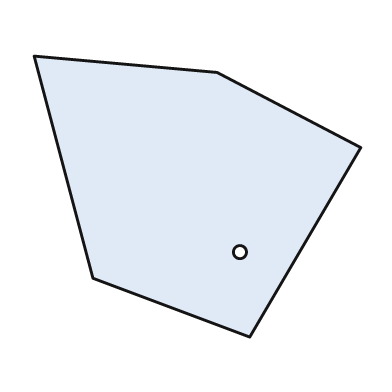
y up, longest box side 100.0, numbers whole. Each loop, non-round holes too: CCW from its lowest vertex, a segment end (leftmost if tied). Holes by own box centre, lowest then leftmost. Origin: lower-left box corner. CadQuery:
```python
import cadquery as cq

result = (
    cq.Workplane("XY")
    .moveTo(66.0, 0.0)
    .lineTo(100.0, 58.0)
    .lineTo(56.0, 81.0)
    .lineTo(0.0, 86.0)
    .lineTo(18.0, 18.0)
    .close()
    .moveTo(63.0, 26.0)
    .circle(2.0)
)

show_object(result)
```